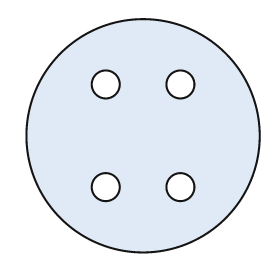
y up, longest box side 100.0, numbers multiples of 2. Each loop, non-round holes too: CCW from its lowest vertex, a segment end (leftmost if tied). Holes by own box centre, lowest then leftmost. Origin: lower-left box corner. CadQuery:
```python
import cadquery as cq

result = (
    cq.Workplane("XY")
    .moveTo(50.0, 50.0)
    .circle(50.0)
    .moveTo(34.0, 28.0)
    .circle(6.0)
    .moveTo(66.0, 28.0)
    .circle(6.0)
    .moveTo(34.0, 72.0)
    .circle(6.0)
    .moveTo(66.0, 72.0)
    .circle(6.0)
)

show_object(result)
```